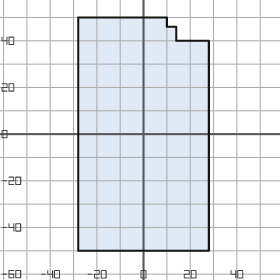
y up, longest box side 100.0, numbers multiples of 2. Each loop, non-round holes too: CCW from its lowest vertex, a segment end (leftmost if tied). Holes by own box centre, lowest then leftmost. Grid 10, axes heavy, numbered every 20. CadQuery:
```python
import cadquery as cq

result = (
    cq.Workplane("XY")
    .moveTo(-28.0, -50.0)
    .lineTo(28.0, -50.0)
    .lineTo(28.0, 40.0)
    .lineTo(14.0, 40.0)
    .lineTo(14.0, 46.0)
    .lineTo(10.0, 46.0)
    .lineTo(10.0, 50.0)
    .lineTo(-28.0, 50.0)
    .close()
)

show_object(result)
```